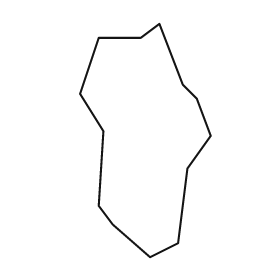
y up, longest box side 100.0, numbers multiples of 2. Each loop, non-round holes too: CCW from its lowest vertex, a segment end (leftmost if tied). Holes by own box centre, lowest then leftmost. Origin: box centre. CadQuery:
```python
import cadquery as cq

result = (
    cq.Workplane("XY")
    .moveTo(2.0, -50.0)
    .lineTo(14.0, -44.0)
    .lineTo(18.0, -12.0)
    .lineTo(28.0, 2.0)
    .lineTo(22.0, 18.0)
    .lineTo(16.0, 24.0)
    .lineTo(6.0, 50.0)
    .lineTo(-2.0, 44.0)
    .lineTo(-20.0, 44.0)
    .lineTo(-28.0, 20.0)
    .lineTo(-18.0, 4.0)
    .lineTo(-20.0, -28.0)
    .lineTo(-14.0, -36.0)
    .close()
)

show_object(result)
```